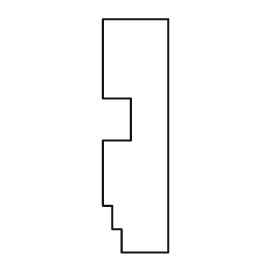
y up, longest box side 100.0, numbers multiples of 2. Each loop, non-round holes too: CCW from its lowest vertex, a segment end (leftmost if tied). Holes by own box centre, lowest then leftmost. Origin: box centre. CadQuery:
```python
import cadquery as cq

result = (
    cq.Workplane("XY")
    .moveTo(-6.0, -50.0)
    .lineTo(14.0, -50.0)
    .lineTo(14.0, 50.0)
    .lineTo(-14.0, 50.0)
    .lineTo(-14.0, 16.0)
    .lineTo(-2.0, 16.0)
    .lineTo(-2.0, -2.0)
    .lineTo(-14.0, -2.0)
    .lineTo(-14.0, -30.0)
    .lineTo(-10.0, -30.0)
    .lineTo(-10.0, -40.0)
    .lineTo(-6.0, -40.0)
    .close()
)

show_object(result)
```